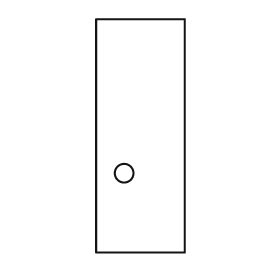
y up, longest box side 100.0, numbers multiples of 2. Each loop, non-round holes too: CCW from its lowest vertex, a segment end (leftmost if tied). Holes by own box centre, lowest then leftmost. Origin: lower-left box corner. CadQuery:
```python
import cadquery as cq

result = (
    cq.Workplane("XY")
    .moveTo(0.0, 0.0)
    .lineTo(38.0, 0.0)
    .lineTo(38.0, 100.0)
    .lineTo(0.0, 100.0)
    .close()
    .moveTo(12.0, 34.0)
    .circle(4.0)
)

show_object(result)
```